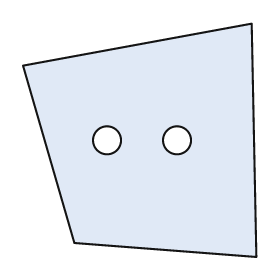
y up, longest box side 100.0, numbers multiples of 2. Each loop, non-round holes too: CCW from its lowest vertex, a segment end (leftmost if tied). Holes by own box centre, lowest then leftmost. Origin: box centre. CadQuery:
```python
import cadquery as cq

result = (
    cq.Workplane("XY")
    .moveTo(50.0, -50.0)
    .lineTo(48.0, 50.0)
    .lineTo(-50.0, 32.0)
    .lineTo(-28.0, -44.0)
    .close()
    .moveTo(-14.0, 0.0)
    .circle(6.0)
    .moveTo(16.0, 0.0)
    .circle(6.0)
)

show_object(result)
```